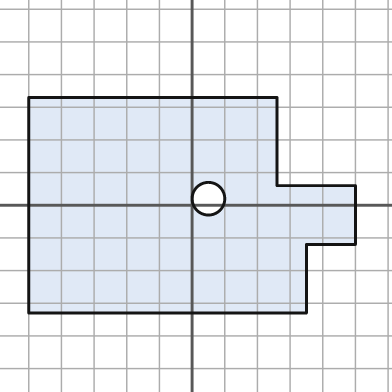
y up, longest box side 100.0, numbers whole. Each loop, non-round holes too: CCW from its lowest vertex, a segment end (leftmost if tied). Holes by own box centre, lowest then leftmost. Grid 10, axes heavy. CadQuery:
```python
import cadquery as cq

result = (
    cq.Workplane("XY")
    .moveTo(-50.0, -33.0)
    .lineTo(35.0, -33.0)
    .lineTo(35.0, -12.0)
    .lineTo(50.0, -12.0)
    .lineTo(50.0, 6.0)
    .lineTo(26.0, 6.0)
    .lineTo(26.0, 33.0)
    .lineTo(-50.0, 33.0)
    .close()
    .moveTo(5.0, 2.0)
    .circle(5.0)
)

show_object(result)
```